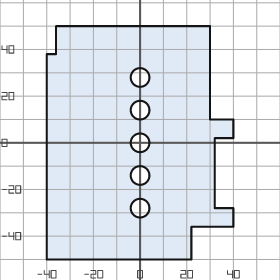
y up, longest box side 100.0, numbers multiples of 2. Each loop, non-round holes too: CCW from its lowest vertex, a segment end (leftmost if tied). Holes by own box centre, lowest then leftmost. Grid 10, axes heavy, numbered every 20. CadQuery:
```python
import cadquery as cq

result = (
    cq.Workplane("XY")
    .moveTo(-40.0, -50.0)
    .lineTo(22.0, -50.0)
    .lineTo(22.0, -36.0)
    .lineTo(40.0, -36.0)
    .lineTo(40.0, -28.0)
    .lineTo(32.0, -28.0)
    .lineTo(32.0, 2.0)
    .lineTo(40.0, 2.0)
    .lineTo(40.0, 10.0)
    .lineTo(30.0, 10.0)
    .lineTo(30.0, 50.0)
    .lineTo(-36.0, 50.0)
    .lineTo(-36.0, 38.0)
    .lineTo(-40.0, 38.0)
    .close()
    .moveTo(0.0, -28.0)
    .circle(4.0)
    .moveTo(0.0, -14.0)
    .circle(4.0)
    .moveTo(0.0, 0.0)
    .circle(4.0)
    .moveTo(0.0, 14.0)
    .circle(4.0)
    .moveTo(0.0, 28.0)
    .circle(4.0)
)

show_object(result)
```